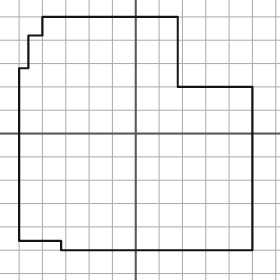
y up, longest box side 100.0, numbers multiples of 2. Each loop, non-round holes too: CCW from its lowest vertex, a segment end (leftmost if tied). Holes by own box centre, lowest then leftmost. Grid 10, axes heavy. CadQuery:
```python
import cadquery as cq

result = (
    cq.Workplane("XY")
    .moveTo(-32.0, -50.0)
    .lineTo(50.0, -50.0)
    .lineTo(50.0, 20.0)
    .lineTo(18.0, 20.0)
    .lineTo(18.0, 50.0)
    .lineTo(-40.0, 50.0)
    .lineTo(-40.0, 42.0)
    .lineTo(-46.0, 42.0)
    .lineTo(-46.0, 28.0)
    .lineTo(-50.0, 28.0)
    .lineTo(-50.0, -46.0)
    .lineTo(-32.0, -46.0)
    .close()
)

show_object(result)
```